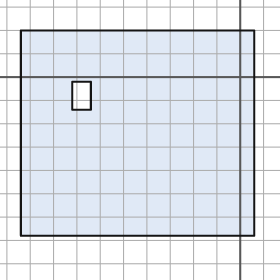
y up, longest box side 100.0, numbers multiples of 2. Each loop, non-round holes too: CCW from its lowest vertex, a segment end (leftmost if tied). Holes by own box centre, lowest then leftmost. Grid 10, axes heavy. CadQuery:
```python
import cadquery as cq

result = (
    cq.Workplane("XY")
    .moveTo(-94.0, -68.0)
    .lineTo(6.0, -68.0)
    .lineTo(6.0, 20.0)
    .lineTo(-94.0, 20.0)
    .close()
    .moveTo(-72.0, -14.0)
    .lineTo(-64.0, -14.0)
    .lineTo(-64.0, -2.0)
    .lineTo(-72.0, -2.0)
    .close()
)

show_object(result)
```